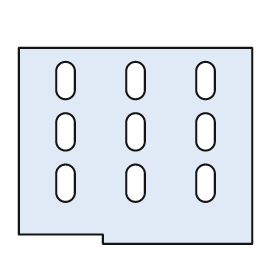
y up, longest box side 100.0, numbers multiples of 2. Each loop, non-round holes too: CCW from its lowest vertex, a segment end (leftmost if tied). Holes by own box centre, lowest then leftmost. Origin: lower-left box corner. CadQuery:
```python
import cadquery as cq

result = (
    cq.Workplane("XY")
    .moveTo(36.0, 0.0)
    .lineTo(100.0, 0.0)
    .lineTo(100.0, 84.0)
    .lineTo(0.0, 84.0)
    .lineTo(0.0, 4.0)
    .lineTo(36.0, 4.0)
    .close()
    .moveTo(16.0, 22.0)
    .threePointArc((20.0, 18.0), (24.0, 22.0))
    .lineTo(24.0, 30.0)
    .threePointArc((20.0, 34.0), (16.0, 30.0))
    .close()
    .moveTo(46.0, 22.0)
    .threePointArc((50.0, 18.0), (54.0, 22.0))
    .lineTo(54.0, 30.0)
    .threePointArc((50.0, 34.0), (46.0, 30.0))
    .close()
    .moveTo(76.0, 22.0)
    .threePointArc((80.0, 18.0), (84.0, 22.0))
    .lineTo(84.0, 30.0)
    .threePointArc((80.0, 34.0), (76.0, 30.0))
    .close()
    .moveTo(16.0, 44.0)
    .threePointArc((20.0, 40.0), (24.0, 44.0))
    .lineTo(24.0, 52.0)
    .threePointArc((20.0, 56.0), (16.0, 52.0))
    .close()
    .moveTo(46.0, 44.0)
    .threePointArc((50.0, 40.0), (54.0, 44.0))
    .lineTo(54.0, 52.0)
    .threePointArc((50.0, 56.0), (46.0, 52.0))
    .close()
    .moveTo(76.0, 44.0)
    .threePointArc((80.0, 40.0), (84.0, 44.0))
    .lineTo(84.0, 52.0)
    .threePointArc((80.0, 56.0), (76.0, 52.0))
    .close()
    .moveTo(16.0, 66.0)
    .threePointArc((20.0, 62.0), (24.0, 66.0))
    .lineTo(24.0, 74.0)
    .threePointArc((20.0, 78.0), (16.0, 74.0))
    .close()
    .moveTo(46.0, 66.0)
    .threePointArc((50.0, 62.0), (54.0, 66.0))
    .lineTo(54.0, 74.0)
    .threePointArc((50.0, 78.0), (46.0, 74.0))
    .close()
    .moveTo(76.0, 66.0)
    .threePointArc((80.0, 62.0), (84.0, 66.0))
    .lineTo(84.0, 74.0)
    .threePointArc((80.0, 78.0), (76.0, 74.0))
    .close()
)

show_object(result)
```